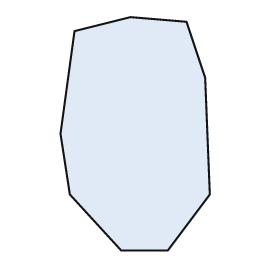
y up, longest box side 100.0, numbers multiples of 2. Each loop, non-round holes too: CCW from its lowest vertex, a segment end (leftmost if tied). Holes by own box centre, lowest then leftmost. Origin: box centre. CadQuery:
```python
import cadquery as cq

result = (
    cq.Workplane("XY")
    .moveTo(-6.0, -50.0)
    .lineTo(14.0, -50.0)
    .lineTo(32.0, -26.0)
    .lineTo(30.0, 24.0)
    .lineTo(22.0, 48.0)
    .lineTo(-2.0, 50.0)
    .lineTo(-26.0, 44.0)
    .lineTo(-32.0, 0.0)
    .lineTo(-28.0, -26.0)
    .close()
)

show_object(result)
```